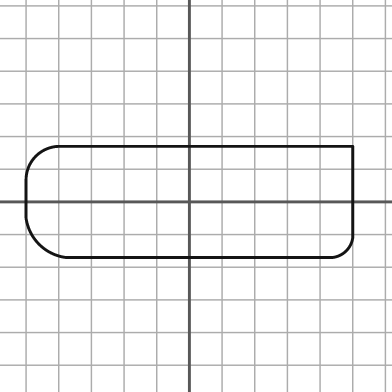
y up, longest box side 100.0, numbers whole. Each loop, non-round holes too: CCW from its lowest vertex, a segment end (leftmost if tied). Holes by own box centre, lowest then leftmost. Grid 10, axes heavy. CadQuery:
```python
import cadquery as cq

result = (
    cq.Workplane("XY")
    .moveTo(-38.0, -17.0)
    .lineTo(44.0, -17.0)
    .threePointArc((48.0, -15.0), (50.0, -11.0))
    .lineTo(50.0, 17.0)
    .lineTo(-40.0, 17.0)
    .threePointArc((-47.0, 14.0), (-50.0, 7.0))
    .lineTo(-50.0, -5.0)
    .threePointArc((-46.0, -13.0), (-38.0, -17.0))
    .close()
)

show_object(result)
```